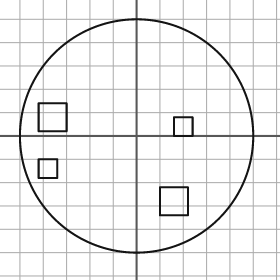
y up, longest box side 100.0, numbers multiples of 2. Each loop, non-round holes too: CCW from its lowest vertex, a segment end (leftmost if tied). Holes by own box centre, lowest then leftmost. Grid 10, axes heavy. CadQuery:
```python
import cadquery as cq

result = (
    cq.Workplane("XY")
    .moveTo(0.0, 0.0)
    .circle(50.0)
    .moveTo(10.0, -34.0)
    .lineTo(22.0, -34.0)
    .lineTo(22.0, -22.0)
    .lineTo(10.0, -22.0)
    .close()
    .moveTo(-42.0, -18.0)
    .lineTo(-34.0, -18.0)
    .lineTo(-34.0, -10.0)
    .lineTo(-42.0, -10.0)
    .close()
    .moveTo(16.0, 0.0)
    .lineTo(24.0, 0.0)
    .lineTo(24.0, 8.0)
    .lineTo(16.0, 8.0)
    .close()
    .moveTo(-42.0, 2.0)
    .lineTo(-30.0, 2.0)
    .lineTo(-30.0, 14.0)
    .lineTo(-42.0, 14.0)
    .close()
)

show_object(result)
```